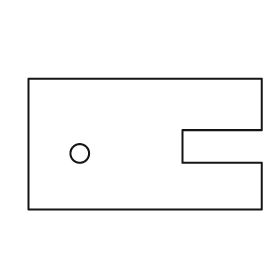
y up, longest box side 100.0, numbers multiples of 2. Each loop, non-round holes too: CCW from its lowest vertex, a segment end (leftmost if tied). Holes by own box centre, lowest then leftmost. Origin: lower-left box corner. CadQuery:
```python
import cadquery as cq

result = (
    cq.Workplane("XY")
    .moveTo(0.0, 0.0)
    .lineTo(100.0, 0.0)
    .lineTo(100.0, 20.0)
    .lineTo(66.0, 20.0)
    .lineTo(66.0, 34.0)
    .lineTo(100.0, 34.0)
    .lineTo(100.0, 56.0)
    .lineTo(0.0, 56.0)
    .close()
    .moveTo(22.0, 24.0)
    .circle(4.0)
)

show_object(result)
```